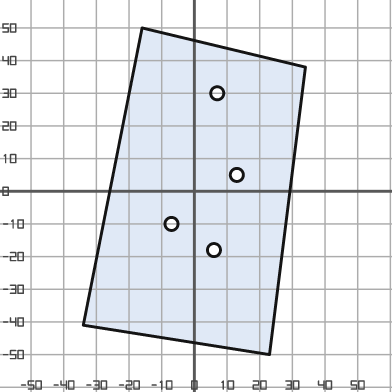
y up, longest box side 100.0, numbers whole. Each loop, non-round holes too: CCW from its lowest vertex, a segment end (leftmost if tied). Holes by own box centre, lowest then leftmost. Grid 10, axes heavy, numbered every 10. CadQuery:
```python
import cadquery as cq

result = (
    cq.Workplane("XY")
    .moveTo(23.0, -50.0)
    .lineTo(34.0, 38.0)
    .lineTo(-16.0, 50.0)
    .lineTo(-34.0, -41.0)
    .close()
    .moveTo(6.0, -18.0)
    .circle(2.0)
    .moveTo(-7.0, -10.0)
    .circle(2.0)
    .moveTo(13.0, 5.0)
    .circle(2.0)
    .moveTo(7.0, 30.0)
    .circle(2.0)
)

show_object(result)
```